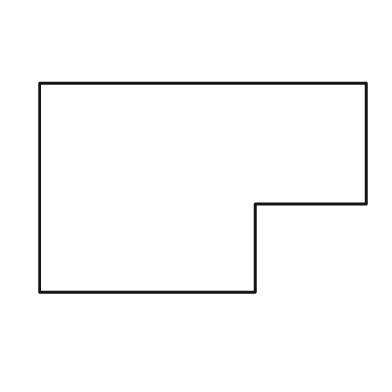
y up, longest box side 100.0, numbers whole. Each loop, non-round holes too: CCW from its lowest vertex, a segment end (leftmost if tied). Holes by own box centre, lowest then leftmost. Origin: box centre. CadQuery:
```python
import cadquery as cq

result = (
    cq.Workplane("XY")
    .moveTo(-50.0, -32.0)
    .lineTo(16.0, -32.0)
    .lineTo(16.0, -5.0)
    .lineTo(50.0, -5.0)
    .lineTo(50.0, 32.0)
    .lineTo(-50.0, 32.0)
    .close()
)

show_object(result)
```